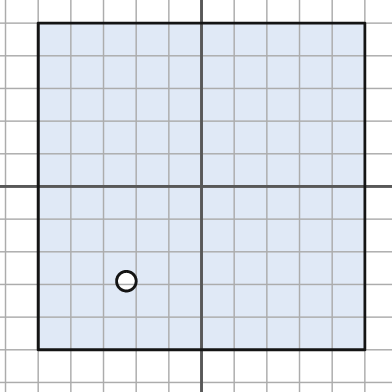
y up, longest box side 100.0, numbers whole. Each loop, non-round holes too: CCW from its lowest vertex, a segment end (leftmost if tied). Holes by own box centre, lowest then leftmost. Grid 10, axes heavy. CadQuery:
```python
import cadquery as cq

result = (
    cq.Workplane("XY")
    .moveTo(-50.0, -50.0)
    .lineTo(50.0, -50.0)
    .lineTo(50.0, 50.0)
    .lineTo(-50.0, 50.0)
    .close()
    .moveTo(-23.0, -29.0)
    .circle(3.0)
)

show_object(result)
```